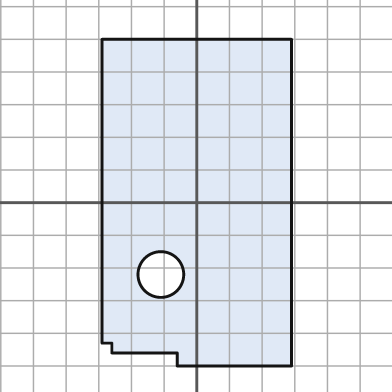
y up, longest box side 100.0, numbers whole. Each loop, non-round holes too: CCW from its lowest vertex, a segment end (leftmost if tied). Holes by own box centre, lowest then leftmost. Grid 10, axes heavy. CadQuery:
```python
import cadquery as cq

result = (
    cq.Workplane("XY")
    .moveTo(-6.0, -50.0)
    .lineTo(29.0, -50.0)
    .lineTo(29.0, 50.0)
    .lineTo(-29.0, 50.0)
    .lineTo(-29.0, -43.0)
    .lineTo(-26.0, -43.0)
    .lineTo(-26.0, -46.0)
    .lineTo(-6.0, -46.0)
    .close()
    .moveTo(-11.0, -22.0)
    .circle(7.0)
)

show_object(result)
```